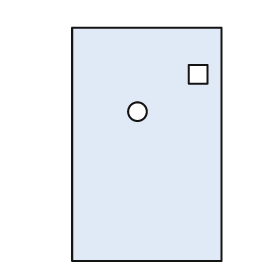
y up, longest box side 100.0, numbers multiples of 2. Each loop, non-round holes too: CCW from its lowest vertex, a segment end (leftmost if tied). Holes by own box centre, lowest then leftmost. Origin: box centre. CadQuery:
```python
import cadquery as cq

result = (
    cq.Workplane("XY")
    .moveTo(-32.0, -50.0)
    .lineTo(32.0, -50.0)
    .lineTo(32.0, 50.0)
    .lineTo(-32.0, 50.0)
    .close()
    .moveTo(-4.0, 14.0)
    .circle(4.0)
    .moveTo(18.0, 26.0)
    .lineTo(26.0, 26.0)
    .lineTo(26.0, 34.0)
    .lineTo(18.0, 34.0)
    .close()
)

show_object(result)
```